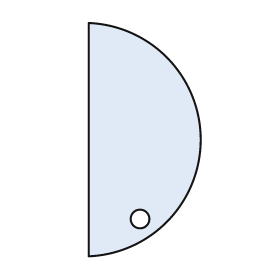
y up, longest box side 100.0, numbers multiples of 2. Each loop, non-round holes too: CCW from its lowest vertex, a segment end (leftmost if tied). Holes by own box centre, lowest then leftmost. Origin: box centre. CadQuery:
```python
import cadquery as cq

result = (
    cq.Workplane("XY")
    .moveTo(-24.0, -50.0)
    .threePointArc((24.0, 0.0), (-24.0, 50.0))
    .close()
    .moveTo(-2.0, -34.0)
    .circle(4.0)
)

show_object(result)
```